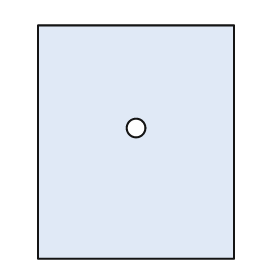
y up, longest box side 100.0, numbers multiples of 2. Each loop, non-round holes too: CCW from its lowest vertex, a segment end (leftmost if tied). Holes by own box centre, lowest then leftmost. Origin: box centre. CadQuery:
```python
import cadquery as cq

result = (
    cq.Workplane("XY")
    .moveTo(-42.0, -50.0)
    .lineTo(42.0, -50.0)
    .lineTo(42.0, 50.0)
    .lineTo(-42.0, 50.0)
    .close()
    .moveTo(0.0, 6.0)
    .circle(4.0)
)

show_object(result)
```